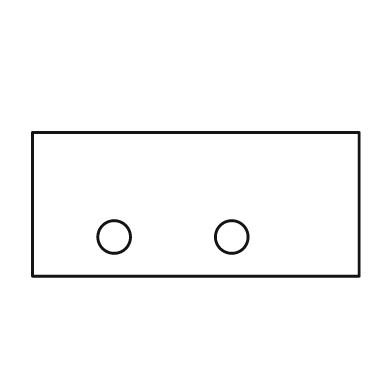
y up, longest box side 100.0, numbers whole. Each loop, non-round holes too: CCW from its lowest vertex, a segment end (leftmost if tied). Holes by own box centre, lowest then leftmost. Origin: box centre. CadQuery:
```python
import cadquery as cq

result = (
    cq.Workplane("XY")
    .moveTo(-50.0, -22.0)
    .lineTo(50.0, -22.0)
    .lineTo(50.0, 22.0)
    .lineTo(-50.0, 22.0)
    .close()
    .moveTo(-25.0, -10.0)
    .circle(5.0)
    .moveTo(11.0, -10.0)
    .circle(5.0)
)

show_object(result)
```